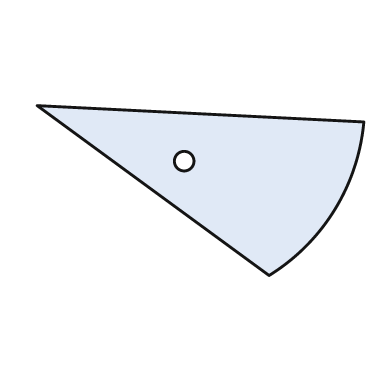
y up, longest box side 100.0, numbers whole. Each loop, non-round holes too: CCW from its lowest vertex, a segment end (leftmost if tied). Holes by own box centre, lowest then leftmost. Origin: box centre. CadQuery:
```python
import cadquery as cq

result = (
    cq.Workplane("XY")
    .moveTo(21.0, -26.0)
    .threePointArc((41.0, -6.0), (50.0, 21.0))
    .lineTo(-50.0, 26.0)
    .close()
    .moveTo(-5.0, 9.0)
    .circle(3.0)
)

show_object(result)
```